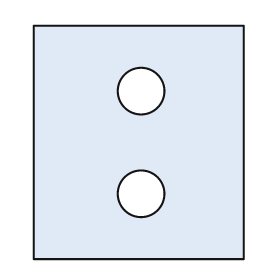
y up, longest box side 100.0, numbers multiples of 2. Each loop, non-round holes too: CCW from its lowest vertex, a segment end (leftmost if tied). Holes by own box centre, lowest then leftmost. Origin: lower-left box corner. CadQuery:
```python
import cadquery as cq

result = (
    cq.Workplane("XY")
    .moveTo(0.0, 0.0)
    .lineTo(90.0, 0.0)
    .lineTo(90.0, 100.0)
    .lineTo(0.0, 100.0)
    .close()
    .moveTo(46.0, 28.0)
    .circle(10.0)
    .moveTo(46.0, 72.0)
    .circle(10.0)
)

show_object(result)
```